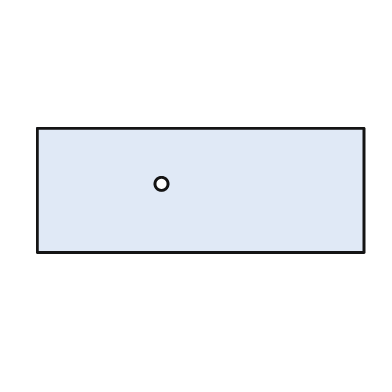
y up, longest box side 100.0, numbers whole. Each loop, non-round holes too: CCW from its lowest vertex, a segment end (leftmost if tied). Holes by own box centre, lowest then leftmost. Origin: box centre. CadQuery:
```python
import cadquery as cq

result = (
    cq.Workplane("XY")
    .moveTo(-50.0, -19.0)
    .lineTo(50.0, -19.0)
    .lineTo(50.0, 19.0)
    .lineTo(-50.0, 19.0)
    .close()
    .moveTo(-12.0, 2.0)
    .circle(2.0)
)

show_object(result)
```